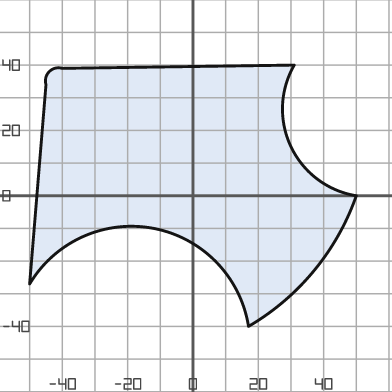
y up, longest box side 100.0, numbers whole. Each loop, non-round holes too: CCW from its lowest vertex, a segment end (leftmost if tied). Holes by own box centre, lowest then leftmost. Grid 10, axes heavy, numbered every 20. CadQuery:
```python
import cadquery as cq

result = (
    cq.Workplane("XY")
    .moveTo(17.0, -40.0)
    .threePointArc((37.0, -23.0), (50.0, 0.0))
    .threePointArc((30.0, 15.0), (31.0, 40.0))
    .lineTo(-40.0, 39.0)
    .threePointArc((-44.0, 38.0), (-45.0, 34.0))
    .lineTo(-50.0, -27.0)
    .threePointArc((-12.0, -10.0), (17.0, -40.0))
    .close()
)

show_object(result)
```